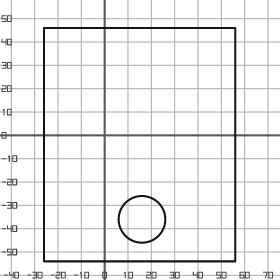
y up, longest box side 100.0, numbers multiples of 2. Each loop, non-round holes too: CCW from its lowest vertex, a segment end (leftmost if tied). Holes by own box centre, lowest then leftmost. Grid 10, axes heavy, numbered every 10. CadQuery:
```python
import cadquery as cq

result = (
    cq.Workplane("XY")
    .moveTo(-26.0, -54.0)
    .lineTo(56.0, -54.0)
    .lineTo(56.0, 46.0)
    .lineTo(-26.0, 46.0)
    .close()
    .moveTo(16.0, -36.0)
    .circle(10.0)
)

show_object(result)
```